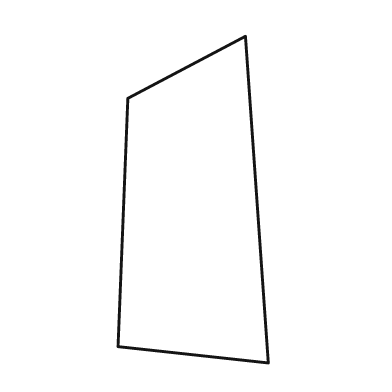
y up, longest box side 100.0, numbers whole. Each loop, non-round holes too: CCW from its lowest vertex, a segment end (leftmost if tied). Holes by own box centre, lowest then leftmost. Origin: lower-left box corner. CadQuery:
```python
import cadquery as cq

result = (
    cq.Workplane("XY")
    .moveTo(46.0, 0.0)
    .lineTo(39.0, 100.0)
    .lineTo(3.0, 81.0)
    .lineTo(0.0, 5.0)
    .close()
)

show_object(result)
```